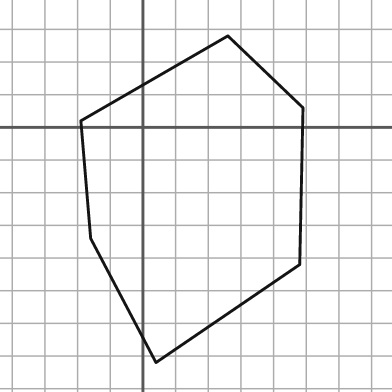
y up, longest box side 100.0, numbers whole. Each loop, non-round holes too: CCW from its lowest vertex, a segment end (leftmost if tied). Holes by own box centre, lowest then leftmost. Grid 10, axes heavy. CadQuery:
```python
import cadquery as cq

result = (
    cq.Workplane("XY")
    .moveTo(4.0, -72.0)
    .lineTo(48.0, -42.0)
    .lineTo(49.0, 6.0)
    .lineTo(26.0, 28.0)
    .lineTo(-19.0, 2.0)
    .lineTo(-16.0, -34.0)
    .close()
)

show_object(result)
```